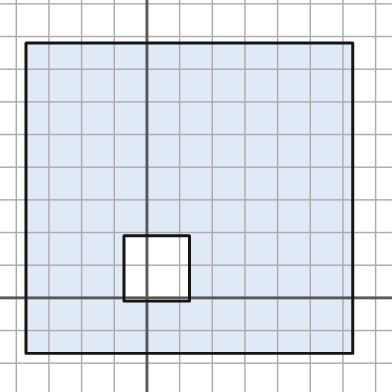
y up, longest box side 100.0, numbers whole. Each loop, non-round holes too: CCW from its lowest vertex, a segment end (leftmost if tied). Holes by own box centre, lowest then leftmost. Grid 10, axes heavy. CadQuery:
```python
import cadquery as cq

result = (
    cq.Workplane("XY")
    .moveTo(-37.0, -17.0)
    .lineTo(63.0, -17.0)
    .lineTo(63.0, 78.0)
    .lineTo(-37.0, 78.0)
    .close()
    .moveTo(-7.0, -1.0)
    .lineTo(13.0, -1.0)
    .lineTo(13.0, 19.0)
    .lineTo(-7.0, 19.0)
    .close()
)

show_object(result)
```